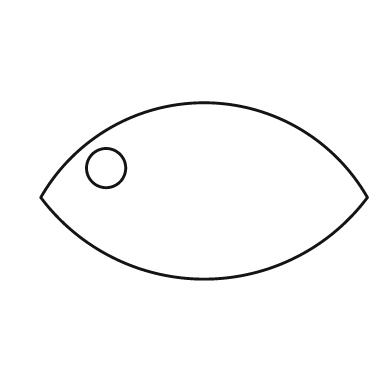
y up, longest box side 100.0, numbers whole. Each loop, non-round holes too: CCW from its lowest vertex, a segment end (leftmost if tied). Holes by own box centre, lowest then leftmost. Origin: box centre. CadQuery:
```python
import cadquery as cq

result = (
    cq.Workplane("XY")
    .moveTo(-50.0, -2.0)
    .threePointArc((0.0, -27.0), (50.0, -2.0))
    .threePointArc((0.0, 27.0), (-50.0, -2.0))
    .close()
    .moveTo(-30.0, 7.0)
    .circle(6.0)
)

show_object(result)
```